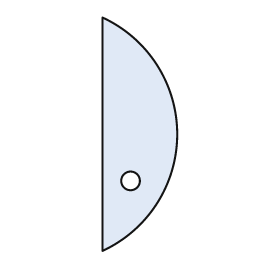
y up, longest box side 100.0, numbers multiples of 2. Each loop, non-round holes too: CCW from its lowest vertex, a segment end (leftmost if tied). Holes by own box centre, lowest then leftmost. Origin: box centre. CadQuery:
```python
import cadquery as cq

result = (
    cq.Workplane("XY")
    .moveTo(-16.0, -50.0)
    .threePointArc((16.0, 0.0), (-16.0, 50.0))
    .close()
    .moveTo(-4.0, -20.0)
    .circle(4.0)
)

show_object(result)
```